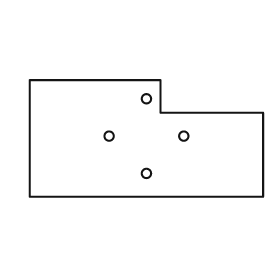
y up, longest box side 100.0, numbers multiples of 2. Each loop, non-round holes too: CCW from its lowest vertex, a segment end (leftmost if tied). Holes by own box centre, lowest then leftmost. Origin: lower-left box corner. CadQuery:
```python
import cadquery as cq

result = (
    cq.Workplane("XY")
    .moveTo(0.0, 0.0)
    .lineTo(100.0, 0.0)
    .lineTo(100.0, 36.0)
    .lineTo(56.0, 36.0)
    .lineTo(56.0, 50.0)
    .lineTo(0.0, 50.0)
    .close()
    .moveTo(50.0, 10.0)
    .circle(2.0)
    .moveTo(34.0, 26.0)
    .circle(2.0)
    .moveTo(66.0, 26.0)
    .circle(2.0)
    .moveTo(50.0, 42.0)
    .circle(2.0)
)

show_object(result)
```